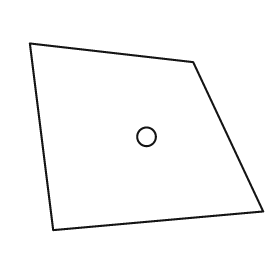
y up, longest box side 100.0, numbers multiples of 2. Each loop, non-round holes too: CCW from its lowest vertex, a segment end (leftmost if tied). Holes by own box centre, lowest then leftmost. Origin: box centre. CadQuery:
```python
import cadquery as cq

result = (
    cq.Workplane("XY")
    .moveTo(-40.0, -40.0)
    .lineTo(50.0, -32.0)
    .lineTo(20.0, 32.0)
    .lineTo(-50.0, 40.0)
    .close()
    .moveTo(0.0, 0.0)
    .circle(4.0)
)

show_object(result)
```